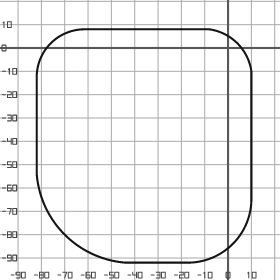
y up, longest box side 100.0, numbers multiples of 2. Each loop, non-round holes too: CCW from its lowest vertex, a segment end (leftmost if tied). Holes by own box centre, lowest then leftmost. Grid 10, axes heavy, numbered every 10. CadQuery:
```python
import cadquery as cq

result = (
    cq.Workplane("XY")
    .moveTo(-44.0, -92.0)
    .lineTo(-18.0, -92.0)
    .threePointArc((2.0, -84.0), (10.0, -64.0))
    .lineTo(10.0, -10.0)
    .threePointArc((4.0, 2.0), (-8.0, 8.0))
    .lineTo(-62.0, 8.0)
    .threePointArc((-76.0, 2.0), (-82.0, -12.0))
    .lineTo(-82.0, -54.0)
    .threePointArc((-70.0, -80.0), (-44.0, -92.0))
    .close()
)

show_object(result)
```